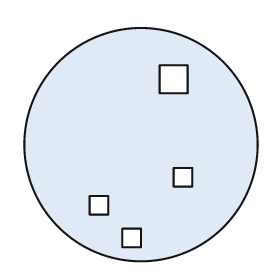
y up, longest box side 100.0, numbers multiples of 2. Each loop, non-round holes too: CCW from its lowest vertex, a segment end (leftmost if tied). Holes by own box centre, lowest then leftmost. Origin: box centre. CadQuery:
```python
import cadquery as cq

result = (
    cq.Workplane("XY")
    .moveTo(0.0, 0.0)
    .circle(50.0)
    .moveTo(-8.0, -44.0)
    .lineTo(0.0, -44.0)
    .lineTo(0.0, -36.0)
    .lineTo(-8.0, -36.0)
    .close()
    .moveTo(-22.0, -30.0)
    .lineTo(-14.0, -30.0)
    .lineTo(-14.0, -22.0)
    .lineTo(-22.0, -22.0)
    .close()
    .moveTo(14.0, -18.0)
    .lineTo(22.0, -18.0)
    .lineTo(22.0, -10.0)
    .lineTo(14.0, -10.0)
    .close()
    .moveTo(8.0, 22.0)
    .lineTo(20.0, 22.0)
    .lineTo(20.0, 34.0)
    .lineTo(8.0, 34.0)
    .close()
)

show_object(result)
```